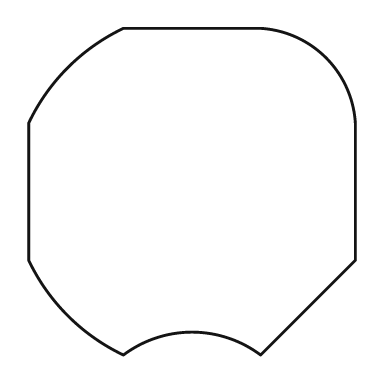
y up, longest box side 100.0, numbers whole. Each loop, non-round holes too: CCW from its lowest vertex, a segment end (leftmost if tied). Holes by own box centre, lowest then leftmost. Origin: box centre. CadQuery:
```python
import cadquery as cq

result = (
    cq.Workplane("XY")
    .moveTo(-21.0, -50.0)
    .threePointArc((0.0, -43.0), (21.0, -50.0))
    .lineTo(50.0, -21.0)
    .lineTo(50.0, 21.0)
    .threePointArc((41.0, 41.0), (21.0, 50.0))
    .lineTo(-21.0, 50.0)
    .threePointArc((-38.0, 38.0), (-50.0, 21.0))
    .lineTo(-50.0, -21.0)
    .threePointArc((-38.0, -38.0), (-21.0, -50.0))
    .close()
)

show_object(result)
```